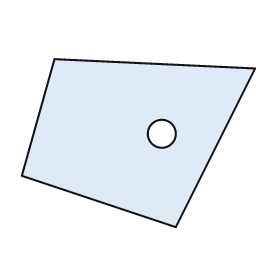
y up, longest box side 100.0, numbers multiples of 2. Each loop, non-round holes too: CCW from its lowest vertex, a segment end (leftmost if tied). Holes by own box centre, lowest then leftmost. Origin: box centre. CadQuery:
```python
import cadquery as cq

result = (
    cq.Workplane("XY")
    .moveTo(16.0, -36.0)
    .lineTo(50.0, 32.0)
    .lineTo(-36.0, 36.0)
    .lineTo(-50.0, -14.0)
    .close()
    .moveTo(10.0, 4.0)
    .circle(6.0)
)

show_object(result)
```